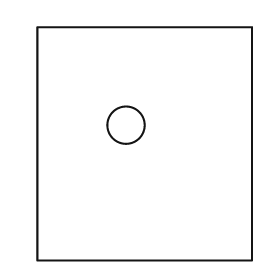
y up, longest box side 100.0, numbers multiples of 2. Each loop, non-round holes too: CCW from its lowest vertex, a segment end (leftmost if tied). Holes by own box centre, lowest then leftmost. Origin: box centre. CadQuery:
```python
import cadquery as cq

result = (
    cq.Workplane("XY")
    .moveTo(-46.0, -50.0)
    .lineTo(46.0, -50.0)
    .lineTo(46.0, 50.0)
    .lineTo(-46.0, 50.0)
    .close()
    .moveTo(-8.0, 8.0)
    .circle(8.0)
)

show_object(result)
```